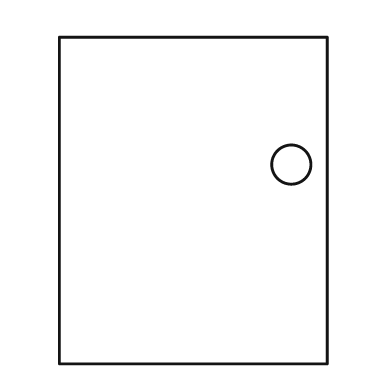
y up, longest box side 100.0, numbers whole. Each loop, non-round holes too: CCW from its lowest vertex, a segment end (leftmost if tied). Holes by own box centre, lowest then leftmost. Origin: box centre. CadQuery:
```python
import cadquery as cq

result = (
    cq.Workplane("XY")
    .moveTo(-41.0, -50.0)
    .lineTo(41.0, -50.0)
    .lineTo(41.0, 50.0)
    .lineTo(-41.0, 50.0)
    .close()
    .moveTo(30.0, 11.0)
    .circle(6.0)
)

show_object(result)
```